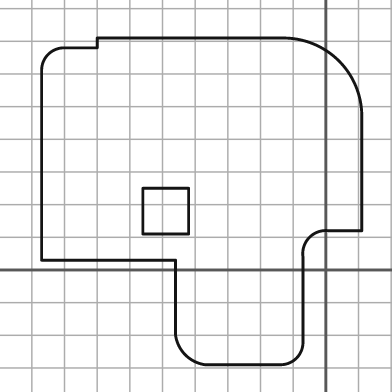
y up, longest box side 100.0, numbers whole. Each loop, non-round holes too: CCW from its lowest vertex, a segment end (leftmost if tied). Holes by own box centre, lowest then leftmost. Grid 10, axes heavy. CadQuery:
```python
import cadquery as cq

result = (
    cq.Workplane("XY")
    .moveTo(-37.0, -29.0)
    .lineTo(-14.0, -29.0)
    .threePointArc((-9.0, -27.0), (-7.0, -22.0))
    .lineTo(-7.0, 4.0)
    .threePointArc((-5.0, 10.0), (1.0, 12.0))
    .lineTo(11.0, 12.0)
    .lineTo(11.0, 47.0)
    .threePointArc((4.0, 64.0), (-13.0, 71.0))
    .lineTo(-70.0, 71.0)
    .lineTo(-70.0, 68.0)
    .lineTo(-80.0, 68.0)
    .threePointArc((-85.0, 66.0), (-87.0, 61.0))
    .lineTo(-87.0, 3.0)
    .lineTo(-46.0, 3.0)
    .lineTo(-46.0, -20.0)
    .threePointArc((-43.0, -26.0), (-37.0, -29.0))
    .close()
    .moveTo(-56.0, 11.0)
    .lineTo(-42.0, 11.0)
    .lineTo(-42.0, 25.0)
    .lineTo(-56.0, 25.0)
    .close()
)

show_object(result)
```